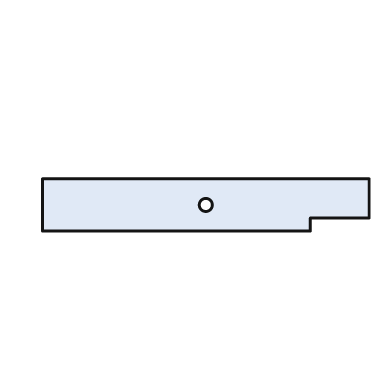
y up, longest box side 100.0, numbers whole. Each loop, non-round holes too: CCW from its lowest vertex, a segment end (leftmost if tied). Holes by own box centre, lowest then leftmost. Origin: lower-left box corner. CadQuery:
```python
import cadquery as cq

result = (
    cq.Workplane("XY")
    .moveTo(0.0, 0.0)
    .lineTo(82.0, 0.0)
    .lineTo(82.0, 4.0)
    .lineTo(100.0, 4.0)
    .lineTo(100.0, 16.0)
    .lineTo(0.0, 16.0)
    .close()
    .moveTo(50.0, 8.0)
    .circle(2.0)
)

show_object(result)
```